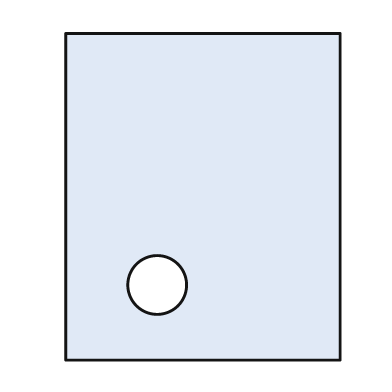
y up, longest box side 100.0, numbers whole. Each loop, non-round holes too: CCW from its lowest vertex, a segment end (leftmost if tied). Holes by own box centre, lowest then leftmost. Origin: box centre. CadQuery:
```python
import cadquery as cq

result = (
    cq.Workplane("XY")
    .moveTo(-42.0, -50.0)
    .lineTo(42.0, -50.0)
    .lineTo(42.0, 50.0)
    .lineTo(-42.0, 50.0)
    .close()
    .moveTo(-14.0, -27.0)
    .circle(9.0)
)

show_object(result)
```